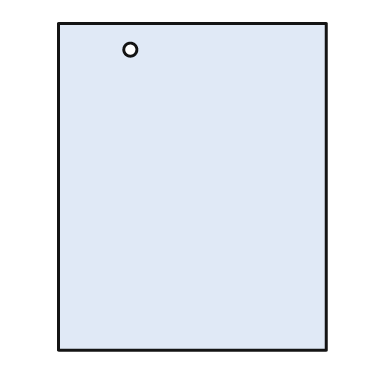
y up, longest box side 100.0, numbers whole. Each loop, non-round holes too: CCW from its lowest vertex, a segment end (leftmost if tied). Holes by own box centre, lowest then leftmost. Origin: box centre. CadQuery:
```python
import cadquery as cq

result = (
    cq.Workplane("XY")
    .moveTo(-41.0, -50.0)
    .lineTo(41.0, -50.0)
    .lineTo(41.0, 50.0)
    .lineTo(-41.0, 50.0)
    .close()
    .moveTo(-19.0, 42.0)
    .circle(2.0)
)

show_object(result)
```